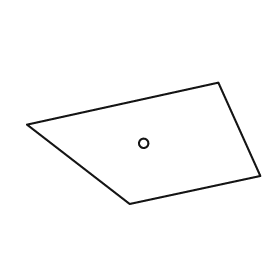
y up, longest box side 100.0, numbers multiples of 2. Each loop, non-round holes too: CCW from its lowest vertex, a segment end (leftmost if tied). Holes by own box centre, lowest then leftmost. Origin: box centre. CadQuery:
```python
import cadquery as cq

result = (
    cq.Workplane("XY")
    .moveTo(-6.0, -26.0)
    .lineTo(50.0, -14.0)
    .lineTo(32.0, 26.0)
    .lineTo(-50.0, 8.0)
    .close()
    .moveTo(0.0, 0.0)
    .circle(2.0)
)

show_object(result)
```